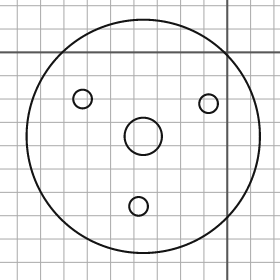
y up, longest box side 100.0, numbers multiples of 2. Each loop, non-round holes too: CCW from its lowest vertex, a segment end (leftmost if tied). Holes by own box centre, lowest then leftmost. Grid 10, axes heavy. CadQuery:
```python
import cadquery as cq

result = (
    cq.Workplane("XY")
    .moveTo(-36.0, -36.0)
    .circle(50.0)
    .moveTo(-38.0, -66.0)
    .circle(4.0)
    .moveTo(-36.0, -36.0)
    .circle(8.0)
    .moveTo(-8.0, -22.0)
    .circle(4.0)
    .moveTo(-62.0, -20.0)
    .circle(4.0)
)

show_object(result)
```